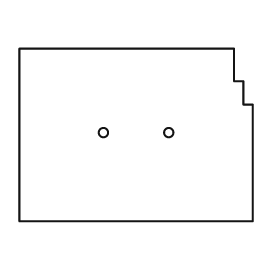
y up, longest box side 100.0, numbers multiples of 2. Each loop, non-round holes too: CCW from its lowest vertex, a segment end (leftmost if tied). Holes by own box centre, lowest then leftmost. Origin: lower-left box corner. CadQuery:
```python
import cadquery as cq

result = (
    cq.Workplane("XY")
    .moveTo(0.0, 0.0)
    .lineTo(100.0, 0.0)
    .lineTo(100.0, 50.0)
    .lineTo(96.0, 50.0)
    .lineTo(96.0, 60.0)
    .lineTo(92.0, 60.0)
    .lineTo(92.0, 74.0)
    .lineTo(0.0, 74.0)
    .close()
    .moveTo(36.0, 38.0)
    .circle(2.0)
    .moveTo(64.0, 38.0)
    .circle(2.0)
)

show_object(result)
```